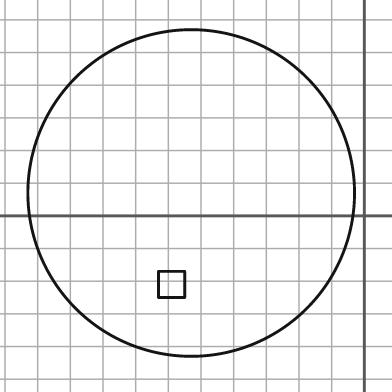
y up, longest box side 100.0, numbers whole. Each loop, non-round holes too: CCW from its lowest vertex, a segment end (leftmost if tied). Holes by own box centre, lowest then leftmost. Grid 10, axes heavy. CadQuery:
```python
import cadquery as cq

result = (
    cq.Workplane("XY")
    .moveTo(-53.0, 7.0)
    .circle(50.0)
    .moveTo(-63.0, -25.0)
    .lineTo(-55.0, -25.0)
    .lineTo(-55.0, -17.0)
    .lineTo(-63.0, -17.0)
    .close()
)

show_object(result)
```